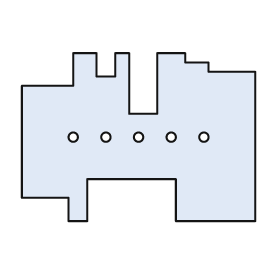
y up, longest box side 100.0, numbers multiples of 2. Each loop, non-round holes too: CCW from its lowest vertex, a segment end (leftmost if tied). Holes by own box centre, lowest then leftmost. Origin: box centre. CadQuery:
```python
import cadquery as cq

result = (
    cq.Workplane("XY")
    .moveTo(-30.0, -36.0)
    .lineTo(-22.0, -36.0)
    .lineTo(-22.0, -18.0)
    .lineTo(16.0, -18.0)
    .lineTo(16.0, -36.0)
    .lineTo(50.0, -36.0)
    .lineTo(50.0, 28.0)
    .lineTo(30.0, 28.0)
    .lineTo(30.0, 32.0)
    .lineTo(20.0, 32.0)
    .lineTo(20.0, 36.0)
    .lineTo(8.0, 36.0)
    .lineTo(8.0, 10.0)
    .lineTo(-4.0, 10.0)
    .lineTo(-4.0, 36.0)
    .lineTo(-10.0, 36.0)
    .lineTo(-10.0, 26.0)
    .lineTo(-18.0, 26.0)
    .lineTo(-18.0, 36.0)
    .lineTo(-28.0, 36.0)
    .lineTo(-28.0, 22.0)
    .lineTo(-50.0, 22.0)
    .lineTo(-50.0, -26.0)
    .lineTo(-30.0, -26.0)
    .close()
    .moveTo(-28.0, 0.0)
    .circle(2.0)
    .moveTo(-14.0, 0.0)
    .circle(2.0)
    .moveTo(0.0, 0.0)
    .circle(2.0)
    .moveTo(14.0, 0.0)
    .circle(2.0)
    .moveTo(28.0, 0.0)
    .circle(2.0)
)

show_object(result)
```